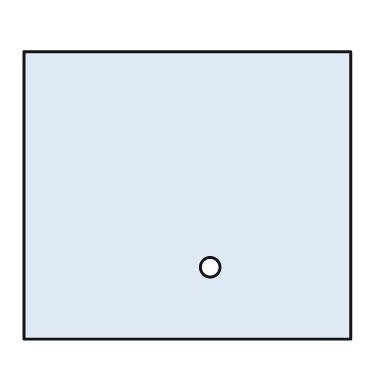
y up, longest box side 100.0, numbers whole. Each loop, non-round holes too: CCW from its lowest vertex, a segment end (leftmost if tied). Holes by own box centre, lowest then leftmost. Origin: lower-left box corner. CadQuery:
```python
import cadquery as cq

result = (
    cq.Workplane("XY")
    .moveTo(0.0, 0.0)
    .lineTo(100.0, 0.0)
    .lineTo(100.0, 88.0)
    .lineTo(0.0, 88.0)
    .close()
    .moveTo(57.0, 22.0)
    .circle(3.0)
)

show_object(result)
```